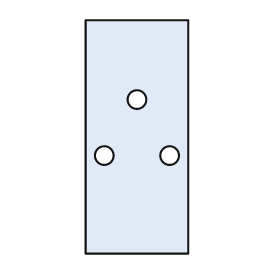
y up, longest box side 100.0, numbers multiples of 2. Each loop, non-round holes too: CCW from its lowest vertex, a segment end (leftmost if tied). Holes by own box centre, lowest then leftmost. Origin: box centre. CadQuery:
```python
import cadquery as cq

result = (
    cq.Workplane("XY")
    .moveTo(-22.0, -50.0)
    .lineTo(22.0, -50.0)
    .lineTo(22.0, 50.0)
    .lineTo(-22.0, 50.0)
    .close()
    .moveTo(-14.0, -8.0)
    .circle(4.0)
    .moveTo(14.0, -8.0)
    .circle(4.0)
    .moveTo(0.0, 16.0)
    .circle(4.0)
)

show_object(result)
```